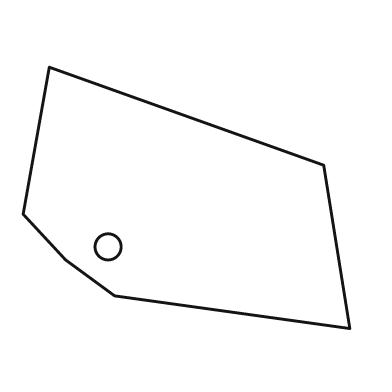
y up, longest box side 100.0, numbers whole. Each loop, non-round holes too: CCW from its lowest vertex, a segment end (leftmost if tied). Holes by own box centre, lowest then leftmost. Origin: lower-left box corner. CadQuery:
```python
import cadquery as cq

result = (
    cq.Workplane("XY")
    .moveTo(100.0, 0.0)
    .lineTo(92.0, 50.0)
    .lineTo(8.0, 80.0)
    .lineTo(0.0, 35.0)
    .lineTo(13.0, 21.0)
    .lineTo(28.0, 10.0)
    .close()
    .moveTo(26.0, 25.0)
    .circle(4.0)
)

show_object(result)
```